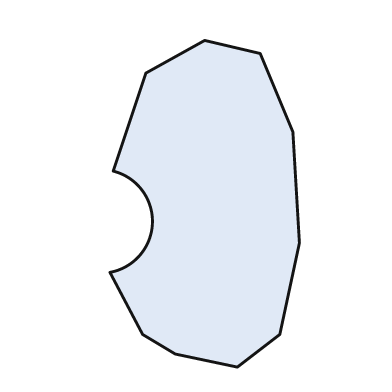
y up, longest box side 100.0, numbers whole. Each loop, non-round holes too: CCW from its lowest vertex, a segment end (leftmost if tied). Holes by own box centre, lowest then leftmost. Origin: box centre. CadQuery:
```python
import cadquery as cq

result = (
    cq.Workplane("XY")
    .moveTo(10.0, -50.0)
    .lineTo(23.0, -40.0)
    .lineTo(29.0, -12.0)
    .lineTo(27.0, 22.0)
    .lineTo(17.0, 46.0)
    .lineTo(0.0, 50.0)
    .lineTo(-18.0, 40.0)
    .lineTo(-28.0, 10.0)
    .threePointArc((-16.0, -6.0), (-29.0, -21.0))
    .lineTo(-19.0, -40.0)
    .lineTo(-9.0, -46.0)
    .close()
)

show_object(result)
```